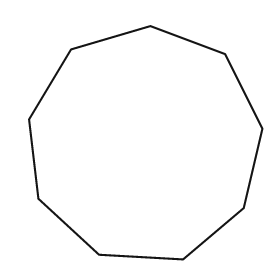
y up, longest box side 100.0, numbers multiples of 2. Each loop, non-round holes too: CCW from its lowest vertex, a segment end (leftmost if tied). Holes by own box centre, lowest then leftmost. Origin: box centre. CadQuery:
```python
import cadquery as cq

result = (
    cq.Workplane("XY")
    .moveTo(16.0, -50.0)
    .lineTo(42.0, -28.0)
    .lineTo(50.0, 6.0)
    .lineTo(34.0, 38.0)
    .lineTo(2.0, 50.0)
    .lineTo(-32.0, 40.0)
    .lineTo(-50.0, 10.0)
    .lineTo(-46.0, -24.0)
    .lineTo(-20.0, -48.0)
    .close()
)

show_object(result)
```